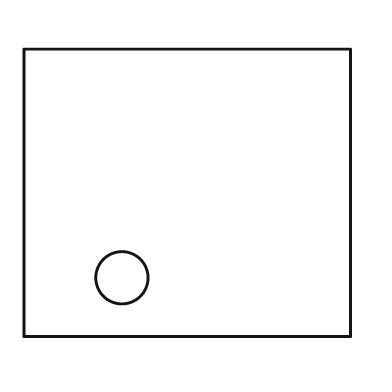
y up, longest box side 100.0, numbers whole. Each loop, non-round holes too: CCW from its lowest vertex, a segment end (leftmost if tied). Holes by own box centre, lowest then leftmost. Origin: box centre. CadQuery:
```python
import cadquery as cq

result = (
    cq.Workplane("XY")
    .moveTo(-50.0, -44.0)
    .lineTo(50.0, -44.0)
    .lineTo(50.0, 44.0)
    .lineTo(-50.0, 44.0)
    .close()
    .moveTo(-20.0, -26.0)
    .circle(8.0)
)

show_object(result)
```